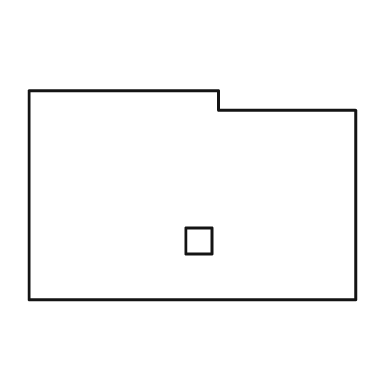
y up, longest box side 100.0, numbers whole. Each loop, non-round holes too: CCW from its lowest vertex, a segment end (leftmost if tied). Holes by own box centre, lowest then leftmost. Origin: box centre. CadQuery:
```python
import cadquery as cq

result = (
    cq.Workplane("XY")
    .moveTo(-50.0, -32.0)
    .lineTo(50.0, -32.0)
    .lineTo(50.0, 26.0)
    .lineTo(8.0, 26.0)
    .lineTo(8.0, 32.0)
    .lineTo(-50.0, 32.0)
    .close()
    .moveTo(-2.0, -18.0)
    .lineTo(6.0, -18.0)
    .lineTo(6.0, -10.0)
    .lineTo(-2.0, -10.0)
    .close()
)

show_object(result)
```